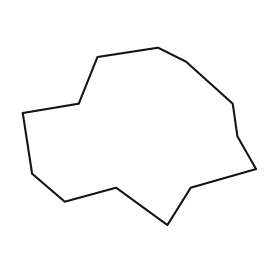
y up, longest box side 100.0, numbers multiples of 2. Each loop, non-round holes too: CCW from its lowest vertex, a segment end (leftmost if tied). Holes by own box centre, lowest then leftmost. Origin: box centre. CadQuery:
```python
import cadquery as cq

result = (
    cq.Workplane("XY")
    .moveTo(12.0, -38.0)
    .lineTo(22.0, -22.0)
    .lineTo(50.0, -14.0)
    .lineTo(42.0, 0.0)
    .lineTo(40.0, 14.0)
    .lineTo(20.0, 32.0)
    .lineTo(8.0, 38.0)
    .lineTo(-18.0, 34.0)
    .lineTo(-26.0, 14.0)
    .lineTo(-50.0, 10.0)
    .lineTo(-46.0, -16.0)
    .lineTo(-32.0, -28.0)
    .lineTo(-10.0, -22.0)
    .close()
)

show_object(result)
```